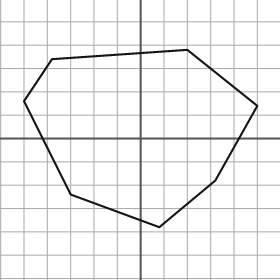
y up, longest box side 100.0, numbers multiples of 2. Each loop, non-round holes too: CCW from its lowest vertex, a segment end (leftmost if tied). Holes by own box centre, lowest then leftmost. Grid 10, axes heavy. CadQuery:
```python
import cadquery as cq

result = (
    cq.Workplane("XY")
    .moveTo(8.0, -38.0)
    .lineTo(32.0, -18.0)
    .lineTo(50.0, 14.0)
    .lineTo(20.0, 38.0)
    .lineTo(-38.0, 34.0)
    .lineTo(-50.0, 16.0)
    .lineTo(-30.0, -24.0)
    .close()
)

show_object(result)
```